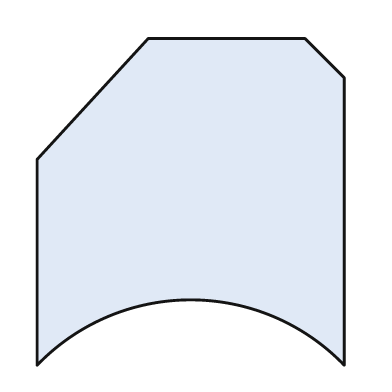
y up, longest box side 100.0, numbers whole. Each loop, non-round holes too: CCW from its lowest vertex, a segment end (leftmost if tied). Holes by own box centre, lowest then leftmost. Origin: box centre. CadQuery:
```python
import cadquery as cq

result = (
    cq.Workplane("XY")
    .moveTo(-47.0, -50.0)
    .threePointArc((0.0, -30.0), (47.0, -50.0))
    .lineTo(47.0, 38.0)
    .lineTo(35.0, 50.0)
    .lineTo(-13.0, 50.0)
    .lineTo(-47.0, 13.0)
    .close()
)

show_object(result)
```